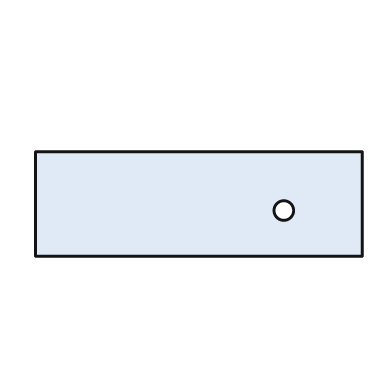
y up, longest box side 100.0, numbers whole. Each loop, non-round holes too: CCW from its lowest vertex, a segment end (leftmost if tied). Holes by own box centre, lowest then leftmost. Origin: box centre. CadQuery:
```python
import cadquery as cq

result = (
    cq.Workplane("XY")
    .moveTo(-50.0, -16.0)
    .lineTo(50.0, -16.0)
    .lineTo(50.0, 16.0)
    .lineTo(-50.0, 16.0)
    .close()
    .moveTo(26.0, -2.0)
    .circle(3.0)
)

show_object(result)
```